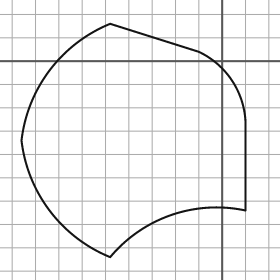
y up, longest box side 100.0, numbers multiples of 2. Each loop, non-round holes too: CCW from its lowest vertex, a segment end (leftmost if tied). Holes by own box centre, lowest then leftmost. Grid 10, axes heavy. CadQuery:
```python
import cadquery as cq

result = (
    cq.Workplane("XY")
    .moveTo(-48.0, -84.0)
    .threePointArc((-22.0, -66.0), (10.0, -64.0))
    .lineTo(10.0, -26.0)
    .threePointArc((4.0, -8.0), (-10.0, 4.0))
    .lineTo(-48.0, 16.0)
    .threePointArc((-74.0, -4.0), (-86.0, -34.0))
    .threePointArc((-74.0, -64.0), (-48.0, -84.0))
    .close()
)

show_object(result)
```